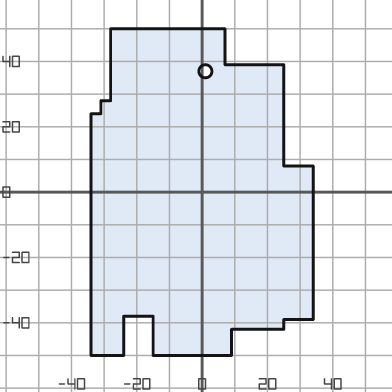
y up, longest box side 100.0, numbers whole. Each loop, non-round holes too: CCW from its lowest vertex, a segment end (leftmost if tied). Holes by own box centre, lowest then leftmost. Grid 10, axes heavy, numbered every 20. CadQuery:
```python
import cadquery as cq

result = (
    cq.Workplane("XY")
    .moveTo(-34.0, -50.0)
    .lineTo(-24.0, -50.0)
    .lineTo(-24.0, -38.0)
    .lineTo(-15.0, -38.0)
    .lineTo(-15.0, -50.0)
    .lineTo(9.0, -50.0)
    .lineTo(9.0, -42.0)
    .lineTo(25.0, -42.0)
    .lineTo(25.0, -39.0)
    .lineTo(34.0, -39.0)
    .lineTo(34.0, 8.0)
    .lineTo(25.0, 8.0)
    .lineTo(25.0, 39.0)
    .lineTo(7.0, 39.0)
    .lineTo(7.0, 50.0)
    .lineTo(-28.0, 50.0)
    .lineTo(-28.0, 28.0)
    .lineTo(-31.0, 28.0)
    .lineTo(-31.0, 24.0)
    .lineTo(-34.0, 24.0)
    .close()
    .moveTo(1.0, 37.0)
    .circle(2.0)
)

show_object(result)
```